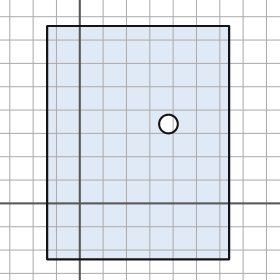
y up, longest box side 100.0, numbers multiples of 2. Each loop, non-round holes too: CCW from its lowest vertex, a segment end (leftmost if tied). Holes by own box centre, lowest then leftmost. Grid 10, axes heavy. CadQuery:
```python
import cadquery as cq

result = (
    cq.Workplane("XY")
    .moveTo(-14.0, -24.0)
    .lineTo(64.0, -24.0)
    .lineTo(64.0, 76.0)
    .lineTo(-14.0, 76.0)
    .close()
    .moveTo(38.0, 34.0)
    .circle(4.0)
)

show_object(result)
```